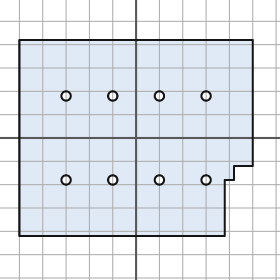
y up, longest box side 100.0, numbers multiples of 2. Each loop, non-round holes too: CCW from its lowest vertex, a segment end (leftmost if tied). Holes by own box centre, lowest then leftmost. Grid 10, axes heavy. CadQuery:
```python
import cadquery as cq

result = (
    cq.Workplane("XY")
    .moveTo(-50.0, -42.0)
    .lineTo(38.0, -42.0)
    .lineTo(38.0, -18.0)
    .lineTo(42.0, -18.0)
    .lineTo(42.0, -12.0)
    .lineTo(50.0, -12.0)
    .lineTo(50.0, 42.0)
    .lineTo(-50.0, 42.0)
    .close()
    .moveTo(-30.0, -18.0)
    .circle(2.0)
    .moveTo(-10.0, -18.0)
    .circle(2.0)
    .moveTo(10.0, -18.0)
    .circle(2.0)
    .moveTo(30.0, -18.0)
    .circle(2.0)
    .moveTo(-30.0, 18.0)
    .circle(2.0)
    .moveTo(-10.0, 18.0)
    .circle(2.0)
    .moveTo(10.0, 18.0)
    .circle(2.0)
    .moveTo(30.0, 18.0)
    .circle(2.0)
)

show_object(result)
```